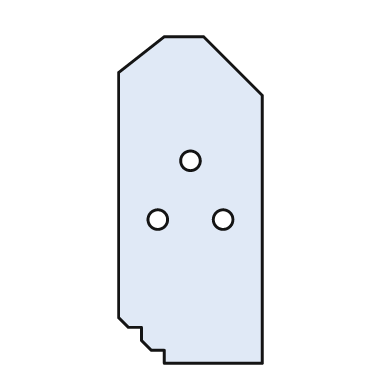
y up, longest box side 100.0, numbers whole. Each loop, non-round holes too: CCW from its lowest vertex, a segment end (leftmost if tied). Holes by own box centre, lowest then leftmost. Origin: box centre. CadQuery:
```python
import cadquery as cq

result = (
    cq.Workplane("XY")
    .moveTo(-8.0, -50.0)
    .lineTo(22.0, -50.0)
    .lineTo(22.0, 32.0)
    .lineTo(4.0, 50.0)
    .lineTo(-8.0, 50.0)
    .lineTo(-22.0, 39.0)
    .lineTo(-22.0, -36.0)
    .lineTo(-19.0, -39.0)
    .lineTo(-15.0, -39.0)
    .lineTo(-15.0, -43.0)
    .lineTo(-12.0, -46.0)
    .lineTo(-8.0, -46.0)
    .close()
    .moveTo(-10.0, -6.0)
    .circle(3.0)
    .moveTo(10.0, -6.0)
    .circle(3.0)
    .moveTo(0.0, 12.0)
    .circle(3.0)
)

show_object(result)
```